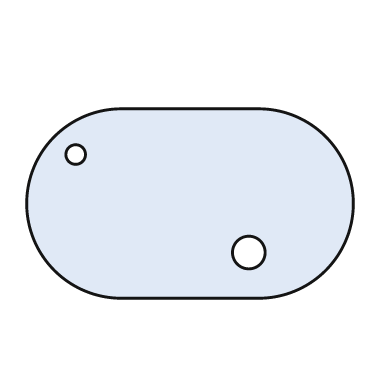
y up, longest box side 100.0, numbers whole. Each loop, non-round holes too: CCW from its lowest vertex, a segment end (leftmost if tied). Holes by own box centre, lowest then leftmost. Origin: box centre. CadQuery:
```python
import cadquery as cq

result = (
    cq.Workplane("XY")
    .moveTo(-21.0, -29.0)
    .lineTo(21.0, -29.0)
    .threePointArc((50.0, 0.0), (21.0, 29.0))
    .lineTo(-21.0, 29.0)
    .threePointArc((-50.0, 0.0), (-21.0, -29.0))
    .close()
    .moveTo(18.0, -15.0)
    .circle(5.0)
    .moveTo(-35.0, 15.0)
    .circle(3.0)
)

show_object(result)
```